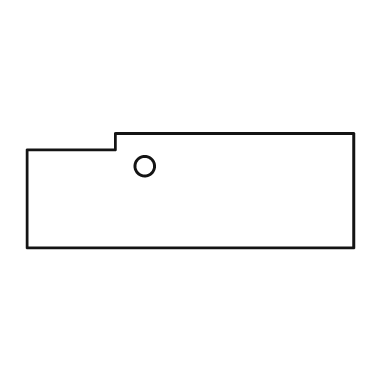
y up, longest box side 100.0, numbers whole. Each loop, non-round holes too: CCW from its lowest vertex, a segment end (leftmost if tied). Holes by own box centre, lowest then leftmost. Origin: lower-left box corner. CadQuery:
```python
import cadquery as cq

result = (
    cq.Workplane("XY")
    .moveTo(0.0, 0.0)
    .lineTo(100.0, 0.0)
    .lineTo(100.0, 35.0)
    .lineTo(27.0, 35.0)
    .lineTo(27.0, 30.0)
    .lineTo(0.0, 30.0)
    .close()
    .moveTo(36.0, 25.0)
    .circle(3.0)
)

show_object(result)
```